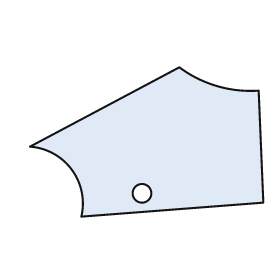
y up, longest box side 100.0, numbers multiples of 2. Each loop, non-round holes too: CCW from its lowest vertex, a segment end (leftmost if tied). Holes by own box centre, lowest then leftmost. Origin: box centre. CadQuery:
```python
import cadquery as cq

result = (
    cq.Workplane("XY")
    .moveTo(-28.0, -32.0)
    .lineTo(50.0, -26.0)
    .lineTo(48.0, 22.0)
    .threePointArc((30.0, 24.0), (14.0, 32.0))
    .lineTo(-50.0, -2.0)
    .threePointArc((-32.0, -12.0), (-28.0, -32.0))
    .close()
    .moveTo(-2.0, -22.0)
    .circle(4.0)
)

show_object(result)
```